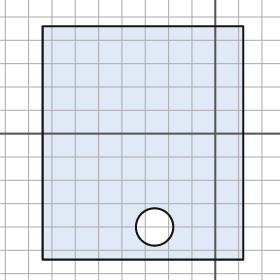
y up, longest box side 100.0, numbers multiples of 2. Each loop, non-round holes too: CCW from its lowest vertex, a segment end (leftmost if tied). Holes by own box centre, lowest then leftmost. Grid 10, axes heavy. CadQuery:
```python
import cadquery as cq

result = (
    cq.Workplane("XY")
    .moveTo(-74.0, -54.0)
    .lineTo(12.0, -54.0)
    .lineTo(12.0, 46.0)
    .lineTo(-74.0, 46.0)
    .close()
    .moveTo(-26.0, -40.0)
    .circle(8.0)
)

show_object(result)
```